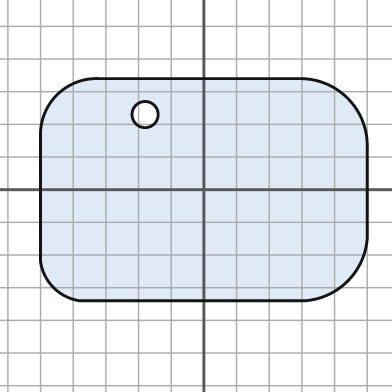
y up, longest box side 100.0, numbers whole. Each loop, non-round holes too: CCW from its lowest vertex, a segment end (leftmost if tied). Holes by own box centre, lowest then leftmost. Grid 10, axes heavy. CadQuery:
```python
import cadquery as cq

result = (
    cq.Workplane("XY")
    .moveTo(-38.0, -34.0)
    .lineTo(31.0, -34.0)
    .threePointArc((44.0, -28.0), (50.0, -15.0))
    .lineTo(50.0, 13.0)
    .threePointArc((44.0, 28.0), (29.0, 34.0))
    .lineTo(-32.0, 34.0)
    .threePointArc((-45.0, 29.0), (-50.0, 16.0))
    .lineTo(-50.0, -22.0)
    .threePointArc((-46.0, -30.0), (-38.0, -34.0))
    .close()
    .moveTo(-18.0, 23.0)
    .circle(4.0)
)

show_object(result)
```